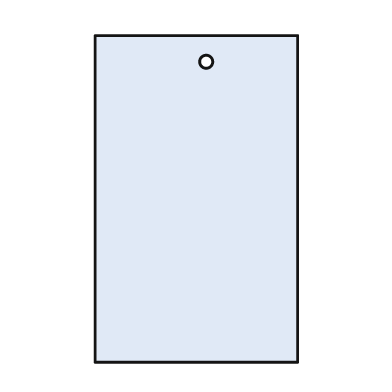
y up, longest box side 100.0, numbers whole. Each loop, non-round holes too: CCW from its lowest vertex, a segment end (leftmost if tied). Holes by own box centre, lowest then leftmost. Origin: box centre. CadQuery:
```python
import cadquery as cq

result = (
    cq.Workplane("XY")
    .moveTo(-31.0, -50.0)
    .lineTo(31.0, -50.0)
    .lineTo(31.0, 50.0)
    .lineTo(-31.0, 50.0)
    .close()
    .moveTo(3.0, 42.0)
    .circle(2.0)
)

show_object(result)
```